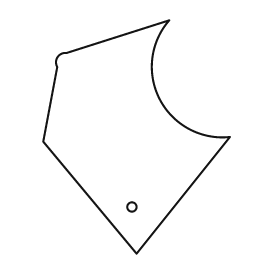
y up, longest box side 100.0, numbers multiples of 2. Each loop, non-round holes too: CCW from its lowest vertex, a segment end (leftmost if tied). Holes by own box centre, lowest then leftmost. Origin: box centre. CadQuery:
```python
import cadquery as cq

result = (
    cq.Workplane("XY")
    .moveTo(0.0, -50.0)
    .lineTo(40.0, 0.0)
    .threePointArc((10.0, 16.0), (14.0, 50.0))
    .lineTo(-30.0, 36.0)
    .threePointArc((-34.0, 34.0), (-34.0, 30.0))
    .lineTo(-40.0, -2.0)
    .close()
    .moveTo(-2.0, -30.0)
    .circle(2.0)
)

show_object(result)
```